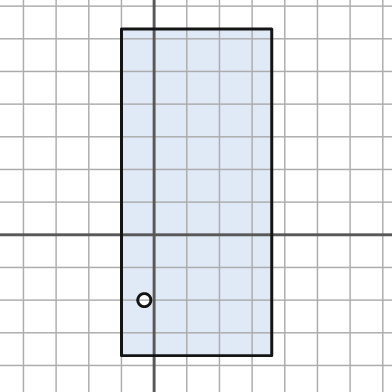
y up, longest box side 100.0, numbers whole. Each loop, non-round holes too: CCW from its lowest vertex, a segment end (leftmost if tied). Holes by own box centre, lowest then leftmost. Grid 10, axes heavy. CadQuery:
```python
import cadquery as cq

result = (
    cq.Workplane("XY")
    .moveTo(-10.0, -37.0)
    .lineTo(36.0, -37.0)
    .lineTo(36.0, 63.0)
    .lineTo(-10.0, 63.0)
    .close()
    .moveTo(-3.0, -20.0)
    .circle(2.0)
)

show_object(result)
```